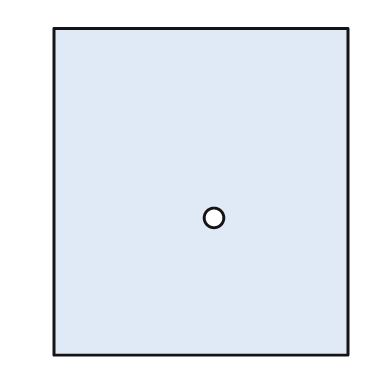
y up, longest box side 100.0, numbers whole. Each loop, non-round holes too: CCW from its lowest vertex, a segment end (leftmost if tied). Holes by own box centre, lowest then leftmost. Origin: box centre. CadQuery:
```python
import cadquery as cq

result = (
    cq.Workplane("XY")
    .moveTo(-45.0, -50.0)
    .lineTo(45.0, -50.0)
    .lineTo(45.0, 50.0)
    .lineTo(-45.0, 50.0)
    .close()
    .moveTo(4.0, -8.0)
    .circle(3.0)
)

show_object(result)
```